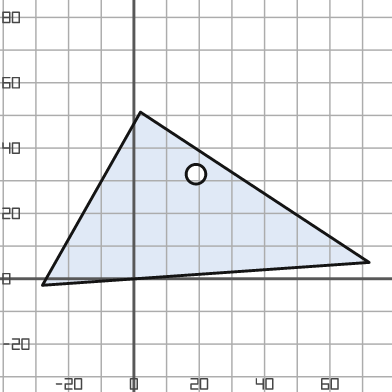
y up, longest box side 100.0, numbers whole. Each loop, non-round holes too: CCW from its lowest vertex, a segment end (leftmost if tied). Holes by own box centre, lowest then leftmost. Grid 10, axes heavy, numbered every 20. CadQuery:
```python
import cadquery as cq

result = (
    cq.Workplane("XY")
    .moveTo(-28.0, -2.0)
    .lineTo(72.0, 5.0)
    .lineTo(2.0, 51.0)
    .close()
    .moveTo(19.0, 32.0)
    .circle(3.0)
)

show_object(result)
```